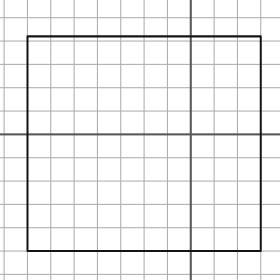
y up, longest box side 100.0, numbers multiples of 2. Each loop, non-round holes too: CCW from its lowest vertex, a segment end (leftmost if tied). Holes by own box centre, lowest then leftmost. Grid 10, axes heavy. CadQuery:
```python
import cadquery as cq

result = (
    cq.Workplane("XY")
    .moveTo(-70.0, -50.0)
    .lineTo(30.0, -50.0)
    .lineTo(30.0, 42.0)
    .lineTo(-70.0, 42.0)
    .close()
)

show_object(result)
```